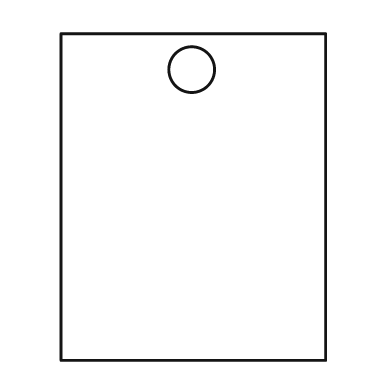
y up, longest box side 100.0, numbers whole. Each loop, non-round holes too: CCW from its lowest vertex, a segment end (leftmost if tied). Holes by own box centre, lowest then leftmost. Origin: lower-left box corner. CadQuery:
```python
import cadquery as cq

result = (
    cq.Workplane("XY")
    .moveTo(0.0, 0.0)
    .lineTo(81.0, 0.0)
    .lineTo(81.0, 100.0)
    .lineTo(0.0, 100.0)
    .close()
    .moveTo(40.0, 89.0)
    .circle(7.0)
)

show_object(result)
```